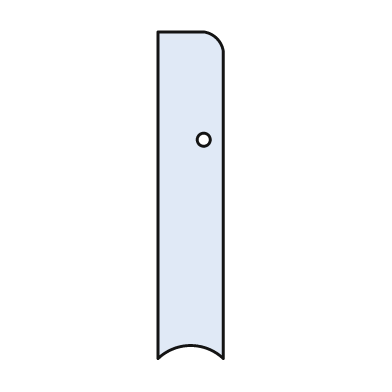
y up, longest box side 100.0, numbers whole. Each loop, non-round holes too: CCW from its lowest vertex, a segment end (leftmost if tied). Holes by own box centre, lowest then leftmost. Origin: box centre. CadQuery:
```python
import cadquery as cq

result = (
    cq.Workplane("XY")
    .moveTo(-10.0, -50.0)
    .threePointArc((0.0, -46.0), (10.0, -50.0))
    .lineTo(10.0, 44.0)
    .threePointArc((8.0, 48.0), (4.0, 50.0))
    .lineTo(-10.0, 50.0)
    .close()
    .moveTo(4.0, 17.0)
    .circle(2.0)
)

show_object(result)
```